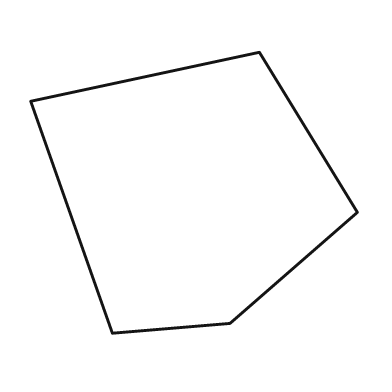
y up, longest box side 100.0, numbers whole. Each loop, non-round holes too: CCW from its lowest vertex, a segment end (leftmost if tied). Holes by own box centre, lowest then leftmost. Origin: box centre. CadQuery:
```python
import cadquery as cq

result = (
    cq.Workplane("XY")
    .moveTo(-25.0, -43.0)
    .lineTo(11.0, -40.0)
    .lineTo(50.0, -6.0)
    .lineTo(20.0, 43.0)
    .lineTo(-50.0, 28.0)
    .close()
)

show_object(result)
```